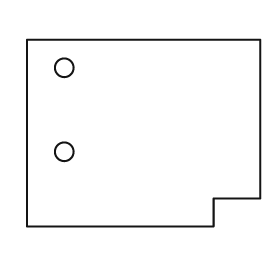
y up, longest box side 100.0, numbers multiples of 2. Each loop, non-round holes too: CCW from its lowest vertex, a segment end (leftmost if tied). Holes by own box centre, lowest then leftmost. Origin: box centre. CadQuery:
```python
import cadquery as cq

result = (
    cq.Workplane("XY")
    .moveTo(-50.0, -40.0)
    .lineTo(30.0, -40.0)
    .lineTo(30.0, -28.0)
    .lineTo(50.0, -28.0)
    .lineTo(50.0, 40.0)
    .lineTo(-50.0, 40.0)
    .close()
    .moveTo(-34.0, -8.0)
    .circle(4.0)
    .moveTo(-34.0, 28.0)
    .circle(4.0)
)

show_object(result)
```